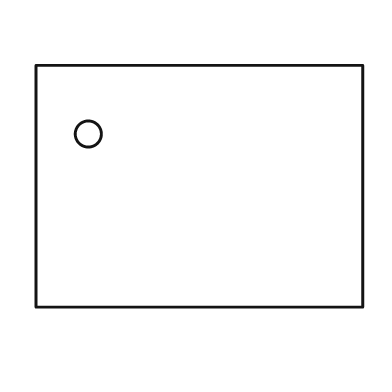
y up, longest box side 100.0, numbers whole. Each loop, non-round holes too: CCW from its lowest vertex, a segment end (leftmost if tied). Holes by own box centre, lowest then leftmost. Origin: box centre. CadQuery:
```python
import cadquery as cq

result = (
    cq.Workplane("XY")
    .moveTo(-50.0, -37.0)
    .lineTo(50.0, -37.0)
    .lineTo(50.0, 37.0)
    .lineTo(-50.0, 37.0)
    .close()
    .moveTo(-34.0, 16.0)
    .circle(4.0)
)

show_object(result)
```